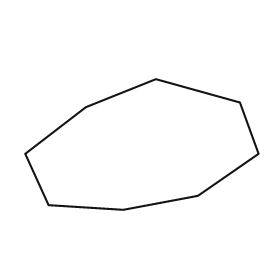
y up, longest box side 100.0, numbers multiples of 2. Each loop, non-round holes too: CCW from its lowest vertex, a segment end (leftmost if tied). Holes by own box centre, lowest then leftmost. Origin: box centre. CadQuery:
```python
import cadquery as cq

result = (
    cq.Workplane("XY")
    .moveTo(-8.0, -28.0)
    .lineTo(24.0, -22.0)
    .lineTo(50.0, -4.0)
    .lineTo(42.0, 18.0)
    .lineTo(6.0, 28.0)
    .lineTo(-24.0, 16.0)
    .lineTo(-50.0, -4.0)
    .lineTo(-40.0, -26.0)
    .close()
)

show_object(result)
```